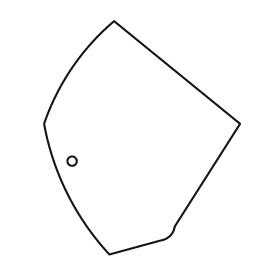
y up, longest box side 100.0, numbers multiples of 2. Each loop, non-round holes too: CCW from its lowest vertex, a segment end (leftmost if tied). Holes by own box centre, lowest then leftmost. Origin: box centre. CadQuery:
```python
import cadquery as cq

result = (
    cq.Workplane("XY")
    .moveTo(-14.0, -50.0)
    .lineTo(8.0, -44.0)
    .threePointArc((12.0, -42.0), (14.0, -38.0))
    .lineTo(42.0, 6.0)
    .lineTo(-12.0, 50.0)
    .threePointArc((-30.0, 30.0), (-42.0, 6.0))
    .threePointArc((-32.0, -24.0), (-14.0, -50.0))
    .close()
    .moveTo(-30.0, -10.0)
    .circle(2.0)
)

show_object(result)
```